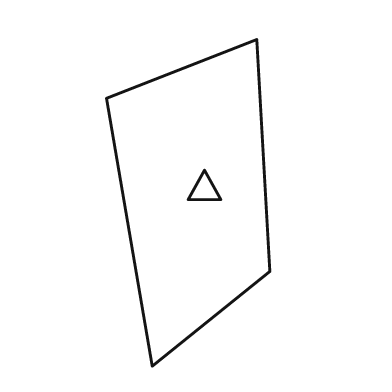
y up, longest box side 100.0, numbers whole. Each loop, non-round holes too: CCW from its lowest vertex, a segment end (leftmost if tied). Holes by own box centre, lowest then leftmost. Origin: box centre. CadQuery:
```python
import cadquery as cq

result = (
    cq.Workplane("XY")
    .moveTo(-11.0, -50.0)
    .lineTo(25.0, -21.0)
    .lineTo(21.0, 50.0)
    .lineTo(-25.0, 32.0)
    .close()
    .moveTo(0.0, 1.0)
    .lineTo(10.0, 1.0)
    .lineTo(5.0, 10.0)
    .close()
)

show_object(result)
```